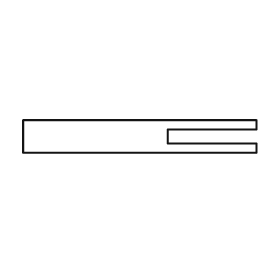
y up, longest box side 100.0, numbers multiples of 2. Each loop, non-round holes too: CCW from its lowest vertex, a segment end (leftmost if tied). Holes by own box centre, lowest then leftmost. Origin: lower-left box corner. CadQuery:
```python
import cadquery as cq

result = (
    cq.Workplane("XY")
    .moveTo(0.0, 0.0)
    .lineTo(100.0, 0.0)
    .lineTo(100.0, 4.0)
    .lineTo(62.0, 4.0)
    .lineTo(62.0, 10.0)
    .lineTo(100.0, 10.0)
    .lineTo(100.0, 14.0)
    .lineTo(0.0, 14.0)
    .close()
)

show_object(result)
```